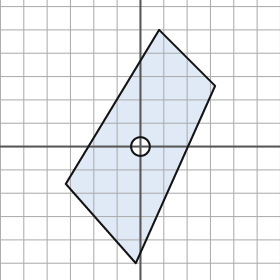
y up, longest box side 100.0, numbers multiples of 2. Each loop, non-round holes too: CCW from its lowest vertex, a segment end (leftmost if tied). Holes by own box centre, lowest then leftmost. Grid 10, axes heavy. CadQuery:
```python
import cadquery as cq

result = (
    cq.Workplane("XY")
    .moveTo(-2.0, -50.0)
    .lineTo(32.0, 26.0)
    .lineTo(8.0, 50.0)
    .lineTo(-32.0, -16.0)
    .close()
    .moveTo(0.0, 0.0)
    .circle(4.0)
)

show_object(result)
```